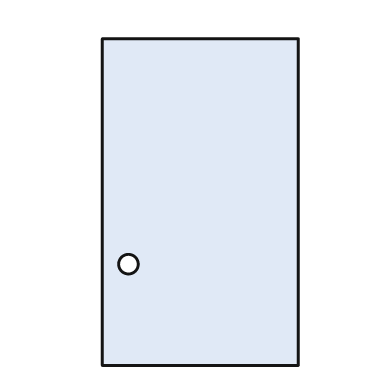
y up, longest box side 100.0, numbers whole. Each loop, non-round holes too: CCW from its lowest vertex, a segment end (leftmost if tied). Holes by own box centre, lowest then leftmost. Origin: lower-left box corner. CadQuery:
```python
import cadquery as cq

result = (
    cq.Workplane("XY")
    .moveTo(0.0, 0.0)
    .lineTo(60.0, 0.0)
    .lineTo(60.0, 100.0)
    .lineTo(0.0, 100.0)
    .close()
    .moveTo(8.0, 31.0)
    .circle(3.0)
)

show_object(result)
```